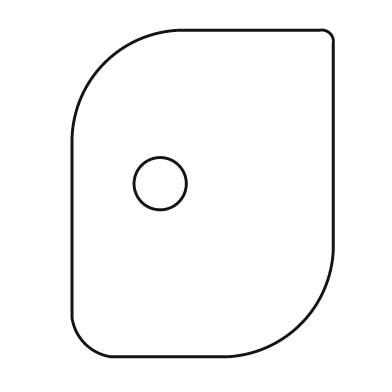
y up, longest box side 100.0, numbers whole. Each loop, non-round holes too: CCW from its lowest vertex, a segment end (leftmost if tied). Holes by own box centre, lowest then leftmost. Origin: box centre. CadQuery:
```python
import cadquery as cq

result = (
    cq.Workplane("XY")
    .moveTo(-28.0, -50.0)
    .lineTo(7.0, -50.0)
    .threePointArc((30.0, -40.0), (40.0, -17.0))
    .lineTo(40.0, 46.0)
    .threePointArc((39.0, 49.0), (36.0, 50.0))
    .lineTo(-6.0, 50.0)
    .threePointArc((-30.0, 40.0), (-40.0, 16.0))
    .lineTo(-40.0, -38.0)
    .threePointArc((-36.0, -46.0), (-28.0, -50.0))
    .close()
    .moveTo(-13.0, 3.0)
    .circle(8.0)
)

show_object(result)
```